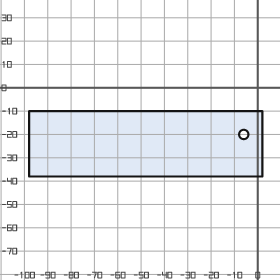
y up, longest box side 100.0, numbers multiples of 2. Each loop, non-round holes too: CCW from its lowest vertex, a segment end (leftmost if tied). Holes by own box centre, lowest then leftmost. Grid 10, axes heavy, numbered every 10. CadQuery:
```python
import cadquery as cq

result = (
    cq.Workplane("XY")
    .moveTo(-98.0, -38.0)
    .lineTo(2.0, -38.0)
    .lineTo(2.0, -10.0)
    .lineTo(-98.0, -10.0)
    .close()
    .moveTo(-6.0, -20.0)
    .circle(2.0)
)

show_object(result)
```